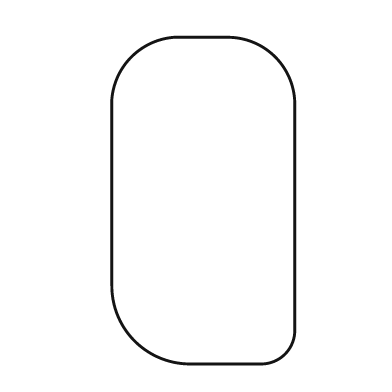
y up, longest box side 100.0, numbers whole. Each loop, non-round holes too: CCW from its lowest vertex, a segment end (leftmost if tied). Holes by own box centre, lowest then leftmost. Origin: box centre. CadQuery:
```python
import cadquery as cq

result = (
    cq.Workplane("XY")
    .moveTo(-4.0, -50.0)
    .lineTo(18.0, -50.0)
    .threePointArc((25.0, -47.0), (28.0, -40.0))
    .lineTo(28.0, 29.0)
    .threePointArc((22.0, 44.0), (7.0, 50.0))
    .lineTo(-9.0, 50.0)
    .threePointArc((-22.0, 44.0), (-28.0, 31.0))
    .lineTo(-28.0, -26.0)
    .threePointArc((-21.0, -43.0), (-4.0, -50.0))
    .close()
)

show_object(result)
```